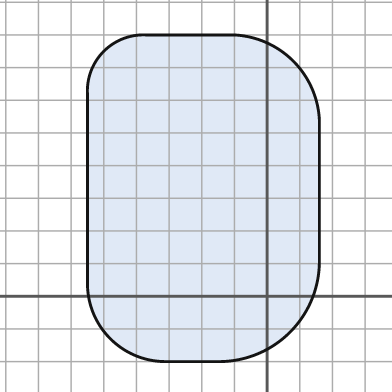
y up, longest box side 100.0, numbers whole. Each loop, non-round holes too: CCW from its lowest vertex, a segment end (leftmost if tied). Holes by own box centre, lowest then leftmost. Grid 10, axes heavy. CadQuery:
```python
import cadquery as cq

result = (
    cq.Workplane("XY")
    .moveTo(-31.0, -20.0)
    .lineTo(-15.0, -20.0)
    .threePointArc((7.0, -11.0), (16.0, 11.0))
    .lineTo(16.0, 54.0)
    .threePointArc((8.0, 72.0), (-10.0, 80.0))
    .lineTo(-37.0, 80.0)
    .threePointArc((-50.0, 75.0), (-55.0, 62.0))
    .lineTo(-55.0, 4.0)
    .threePointArc((-48.0, -13.0), (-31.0, -20.0))
    .close()
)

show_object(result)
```